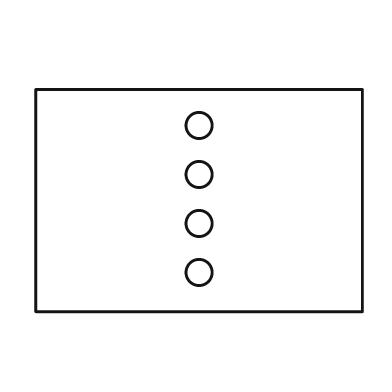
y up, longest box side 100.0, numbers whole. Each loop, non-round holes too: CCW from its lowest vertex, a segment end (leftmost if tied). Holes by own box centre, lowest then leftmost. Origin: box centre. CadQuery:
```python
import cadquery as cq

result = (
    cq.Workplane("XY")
    .moveTo(-50.0, -34.0)
    .lineTo(50.0, -34.0)
    .lineTo(50.0, 34.0)
    .lineTo(-50.0, 34.0)
    .close()
    .moveTo(0.0, -22.0)
    .circle(4.0)
    .moveTo(0.0, -7.0)
    .circle(4.0)
    .moveTo(0.0, 8.0)
    .circle(4.0)
    .moveTo(0.0, 23.0)
    .circle(4.0)
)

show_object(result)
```